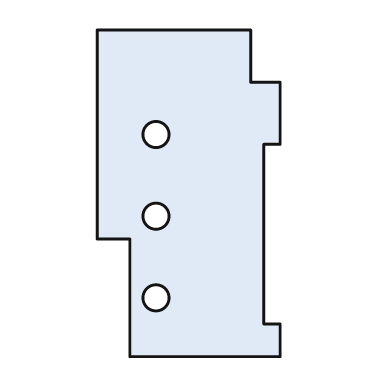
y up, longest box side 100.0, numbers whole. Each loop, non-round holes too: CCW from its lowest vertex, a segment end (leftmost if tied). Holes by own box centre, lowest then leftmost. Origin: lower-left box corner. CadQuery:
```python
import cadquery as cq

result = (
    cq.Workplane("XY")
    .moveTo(10.0, 0.0)
    .lineTo(56.0, 0.0)
    .lineTo(56.0, 10.0)
    .lineTo(51.0, 10.0)
    .lineTo(51.0, 65.0)
    .lineTo(56.0, 65.0)
    .lineTo(56.0, 84.0)
    .lineTo(47.0, 84.0)
    .lineTo(47.0, 100.0)
    .lineTo(0.0, 100.0)
    .lineTo(0.0, 36.0)
    .lineTo(10.0, 36.0)
    .close()
    .moveTo(18.0, 18.0)
    .circle(4.0)
    .moveTo(18.0, 43.0)
    .circle(4.0)
    .moveTo(18.0, 68.0)
    .circle(4.0)
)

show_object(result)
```